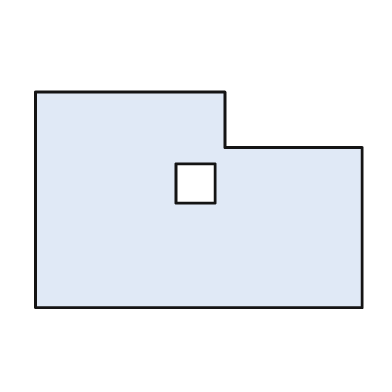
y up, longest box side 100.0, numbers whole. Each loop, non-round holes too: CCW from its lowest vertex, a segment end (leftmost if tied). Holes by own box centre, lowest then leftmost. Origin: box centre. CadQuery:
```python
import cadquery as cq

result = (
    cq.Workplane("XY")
    .moveTo(-50.0, -33.0)
    .lineTo(50.0, -33.0)
    .lineTo(50.0, 16.0)
    .lineTo(8.0, 16.0)
    .lineTo(8.0, 33.0)
    .lineTo(-50.0, 33.0)
    .close()
    .moveTo(-7.0, -1.0)
    .lineTo(5.0, -1.0)
    .lineTo(5.0, 11.0)
    .lineTo(-7.0, 11.0)
    .close()
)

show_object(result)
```